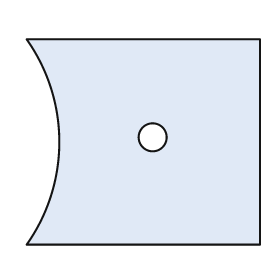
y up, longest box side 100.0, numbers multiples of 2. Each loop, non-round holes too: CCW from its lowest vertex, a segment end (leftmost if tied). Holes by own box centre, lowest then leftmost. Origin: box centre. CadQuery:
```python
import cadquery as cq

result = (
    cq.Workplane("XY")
    .moveTo(-50.0, -44.0)
    .lineTo(50.0, -44.0)
    .lineTo(50.0, 44.0)
    .lineTo(-50.0, 44.0)
    .threePointArc((-36.0, 0.0), (-50.0, -44.0))
    .close()
    .moveTo(4.0, 2.0)
    .circle(6.0)
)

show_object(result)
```